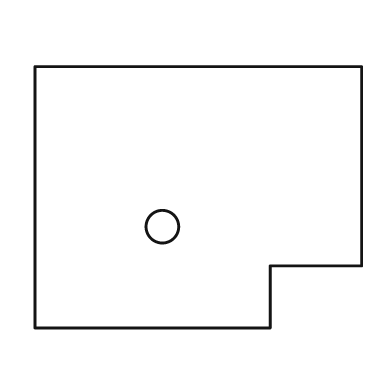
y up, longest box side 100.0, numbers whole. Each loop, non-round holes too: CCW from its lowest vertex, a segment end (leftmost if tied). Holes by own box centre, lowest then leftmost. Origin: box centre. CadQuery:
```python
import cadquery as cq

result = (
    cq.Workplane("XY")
    .moveTo(-50.0, -40.0)
    .lineTo(22.0, -40.0)
    .lineTo(22.0, -21.0)
    .lineTo(50.0, -21.0)
    .lineTo(50.0, 40.0)
    .lineTo(-50.0, 40.0)
    .close()
    .moveTo(-11.0, -9.0)
    .circle(5.0)
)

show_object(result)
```